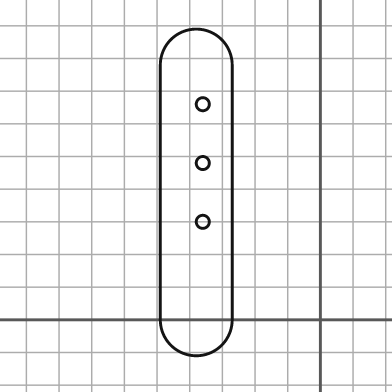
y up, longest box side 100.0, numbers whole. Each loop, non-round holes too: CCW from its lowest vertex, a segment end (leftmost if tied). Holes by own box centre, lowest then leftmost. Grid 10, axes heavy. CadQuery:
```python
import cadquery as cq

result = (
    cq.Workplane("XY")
    .moveTo(-49.0, 0.0)
    .threePointArc((-38.0, -11.0), (-27.0, 0.0))
    .lineTo(-27.0, 78.0)
    .threePointArc((-38.0, 89.0), (-49.0, 78.0))
    .close()
    .moveTo(-36.0, 30.0)
    .circle(2.0)
    .moveTo(-36.0, 48.0)
    .circle(2.0)
    .moveTo(-36.0, 66.0)
    .circle(2.0)
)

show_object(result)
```